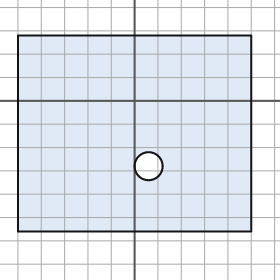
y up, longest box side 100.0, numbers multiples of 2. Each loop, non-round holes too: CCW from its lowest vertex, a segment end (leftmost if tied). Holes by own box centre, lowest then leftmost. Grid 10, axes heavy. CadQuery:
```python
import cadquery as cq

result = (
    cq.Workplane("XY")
    .moveTo(-50.0, -56.0)
    .lineTo(50.0, -56.0)
    .lineTo(50.0, 28.0)
    .lineTo(-50.0, 28.0)
    .close()
    .moveTo(6.0, -28.0)
    .circle(6.0)
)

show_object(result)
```